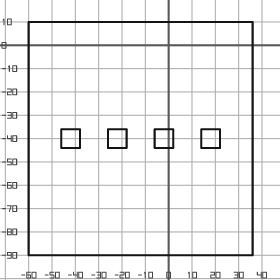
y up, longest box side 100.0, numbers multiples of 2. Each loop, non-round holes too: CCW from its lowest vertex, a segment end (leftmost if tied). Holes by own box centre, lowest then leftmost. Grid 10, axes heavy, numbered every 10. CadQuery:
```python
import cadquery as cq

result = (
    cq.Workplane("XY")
    .moveTo(-60.0, -90.0)
    .lineTo(36.0, -90.0)
    .lineTo(36.0, 10.0)
    .lineTo(-60.0, 10.0)
    .close()
    .moveTo(-46.0, -44.0)
    .lineTo(-38.0, -44.0)
    .lineTo(-38.0, -36.0)
    .lineTo(-46.0, -36.0)
    .close()
    .moveTo(-26.0, -44.0)
    .lineTo(-18.0, -44.0)
    .lineTo(-18.0, -36.0)
    .lineTo(-26.0, -36.0)
    .close()
    .moveTo(-6.0, -44.0)
    .lineTo(2.0, -44.0)
    .lineTo(2.0, -36.0)
    .lineTo(-6.0, -36.0)
    .close()
    .moveTo(14.0, -44.0)
    .lineTo(22.0, -44.0)
    .lineTo(22.0, -36.0)
    .lineTo(14.0, -36.0)
    .close()
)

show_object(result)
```